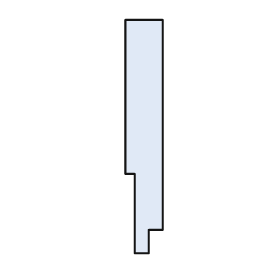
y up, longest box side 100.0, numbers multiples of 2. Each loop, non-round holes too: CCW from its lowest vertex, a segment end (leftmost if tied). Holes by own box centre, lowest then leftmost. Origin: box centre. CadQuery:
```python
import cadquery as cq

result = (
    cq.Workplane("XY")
    .moveTo(-4.0, -50.0)
    .lineTo(2.0, -50.0)
    .lineTo(2.0, -40.0)
    .lineTo(8.0, -40.0)
    .lineTo(8.0, 50.0)
    .lineTo(-8.0, 50.0)
    .lineTo(-8.0, -16.0)
    .lineTo(-4.0, -16.0)
    .close()
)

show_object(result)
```